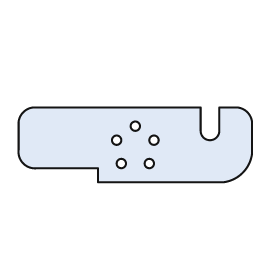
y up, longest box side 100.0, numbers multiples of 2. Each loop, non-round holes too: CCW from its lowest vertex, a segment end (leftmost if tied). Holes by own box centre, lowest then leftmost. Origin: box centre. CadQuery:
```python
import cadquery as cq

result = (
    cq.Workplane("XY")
    .moveTo(-16.0, -16.0)
    .lineTo(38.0, -16.0)
    .threePointArc((46.0, -12.0), (50.0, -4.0))
    .lineTo(50.0, 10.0)
    .threePointArc((48.0, 14.0), (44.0, 16.0))
    .lineTo(36.0, 16.0)
    .lineTo(36.0, 6.0)
    .threePointArc((32.0, 2.0), (28.0, 6.0))
    .lineTo(28.0, 16.0)
    .lineTo(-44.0, 16.0)
    .threePointArc((-48.0, 14.0), (-50.0, 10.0))
    .lineTo(-50.0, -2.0)
    .threePointArc((-48.0, -8.0), (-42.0, -10.0))
    .lineTo(-16.0, -10.0)
    .close()
    .moveTo(-6.0, -8.0)
    .circle(2.0)
    .moveTo(6.0, -8.0)
    .circle(2.0)
    .moveTo(-8.0, 2.0)
    .circle(2.0)
    .moveTo(8.0, 2.0)
    .circle(2.0)
    .moveTo(0.0, 8.0)
    .circle(2.0)
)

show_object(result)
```